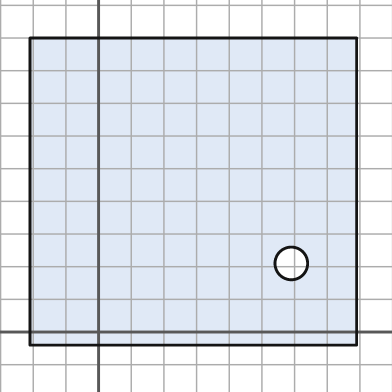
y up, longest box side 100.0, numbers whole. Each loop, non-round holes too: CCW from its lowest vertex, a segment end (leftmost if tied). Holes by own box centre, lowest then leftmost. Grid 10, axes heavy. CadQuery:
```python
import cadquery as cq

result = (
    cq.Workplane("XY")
    .moveTo(-21.0, -4.0)
    .lineTo(79.0, -4.0)
    .lineTo(79.0, 90.0)
    .lineTo(-21.0, 90.0)
    .close()
    .moveTo(59.0, 21.0)
    .circle(5.0)
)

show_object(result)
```